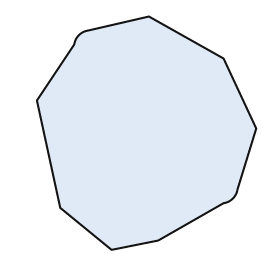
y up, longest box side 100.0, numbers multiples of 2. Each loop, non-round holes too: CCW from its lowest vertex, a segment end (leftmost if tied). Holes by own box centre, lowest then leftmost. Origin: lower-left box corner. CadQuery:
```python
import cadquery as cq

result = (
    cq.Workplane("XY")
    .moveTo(32.0, 0.0)
    .lineTo(52.0, 4.0)
    .lineTo(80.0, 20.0)
    .threePointArc((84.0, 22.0), (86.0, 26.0))
    .lineTo(94.0, 52.0)
    .lineTo(80.0, 82.0)
    .lineTo(48.0, 100.0)
    .lineTo(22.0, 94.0)
    .threePointArc((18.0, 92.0), (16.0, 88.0))
    .lineTo(0.0, 64.0)
    .lineTo(10.0, 18.0)
    .close()
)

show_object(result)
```